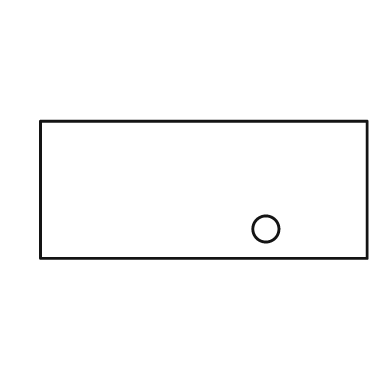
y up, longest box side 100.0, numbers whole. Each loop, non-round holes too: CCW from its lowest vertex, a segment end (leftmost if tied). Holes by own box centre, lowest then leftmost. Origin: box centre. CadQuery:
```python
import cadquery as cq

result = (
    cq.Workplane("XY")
    .moveTo(-50.0, -21.0)
    .lineTo(50.0, -21.0)
    .lineTo(50.0, 21.0)
    .lineTo(-50.0, 21.0)
    .close()
    .moveTo(19.0, -12.0)
    .circle(4.0)
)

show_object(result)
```